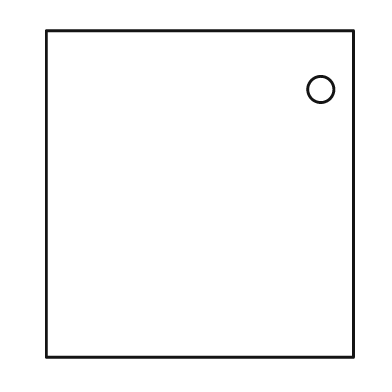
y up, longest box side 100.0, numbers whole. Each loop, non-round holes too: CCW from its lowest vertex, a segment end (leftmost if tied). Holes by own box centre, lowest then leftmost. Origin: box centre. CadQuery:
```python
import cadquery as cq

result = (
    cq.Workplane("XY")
    .moveTo(-47.0, -50.0)
    .lineTo(47.0, -50.0)
    .lineTo(47.0, 50.0)
    .lineTo(-47.0, 50.0)
    .close()
    .moveTo(37.0, 32.0)
    .circle(4.0)
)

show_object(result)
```